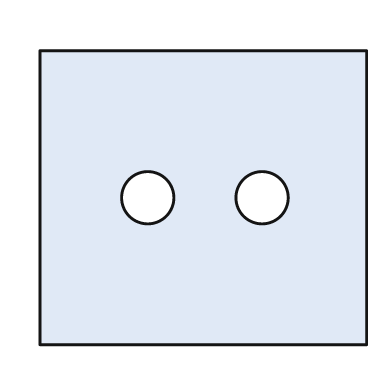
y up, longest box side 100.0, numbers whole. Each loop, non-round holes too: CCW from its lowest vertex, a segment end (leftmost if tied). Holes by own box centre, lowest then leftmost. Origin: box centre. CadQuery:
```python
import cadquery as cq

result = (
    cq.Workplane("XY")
    .moveTo(-50.0, -45.0)
    .lineTo(50.0, -45.0)
    .lineTo(50.0, 45.0)
    .lineTo(-50.0, 45.0)
    .close()
    .moveTo(-17.0, 0.0)
    .circle(8.0)
    .moveTo(18.0, 0.0)
    .circle(8.0)
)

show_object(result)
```